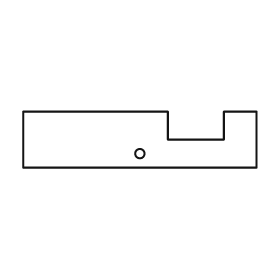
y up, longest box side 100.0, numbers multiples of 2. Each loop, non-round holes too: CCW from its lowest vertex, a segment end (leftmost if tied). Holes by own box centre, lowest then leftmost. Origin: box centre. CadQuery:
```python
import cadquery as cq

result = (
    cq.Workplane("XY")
    .moveTo(-50.0, -12.0)
    .lineTo(50.0, -12.0)
    .lineTo(50.0, 12.0)
    .lineTo(36.0, 12.0)
    .lineTo(36.0, 0.0)
    .lineTo(12.0, 0.0)
    .lineTo(12.0, 12.0)
    .lineTo(-50.0, 12.0)
    .close()
    .moveTo(0.0, -6.0)
    .circle(2.0)
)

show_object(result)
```